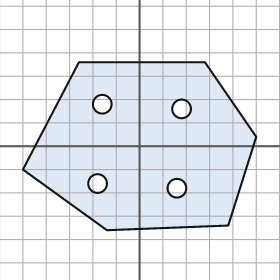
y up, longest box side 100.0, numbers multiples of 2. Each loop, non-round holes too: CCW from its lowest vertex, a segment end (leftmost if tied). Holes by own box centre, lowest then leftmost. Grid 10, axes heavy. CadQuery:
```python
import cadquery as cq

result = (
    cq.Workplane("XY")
    .moveTo(-14.0, -36.0)
    .lineTo(38.0, -34.0)
    .lineTo(50.0, 4.0)
    .lineTo(28.0, 36.0)
    .lineTo(-26.0, 36.0)
    .lineTo(-50.0, -10.0)
    .close()
    .moveTo(16.0, -18.0)
    .circle(4.0)
    .moveTo(-18.0, -16.0)
    .circle(4.0)
    .moveTo(18.0, 16.0)
    .circle(4.0)
    .moveTo(-16.0, 18.0)
    .circle(4.0)
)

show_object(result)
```